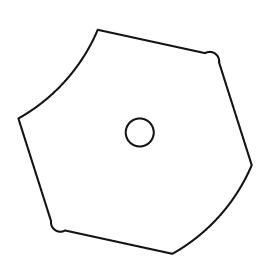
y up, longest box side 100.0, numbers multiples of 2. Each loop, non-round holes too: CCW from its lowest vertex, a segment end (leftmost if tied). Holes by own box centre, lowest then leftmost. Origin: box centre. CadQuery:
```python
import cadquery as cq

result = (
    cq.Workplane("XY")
    .moveTo(16.0, -48.0)
    .threePointArc((36.0, -32.0), (50.0, -10.0))
    .lineTo(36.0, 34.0)
    .threePointArc((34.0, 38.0), (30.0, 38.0))
    .lineTo(-16.0, 48.0)
    .threePointArc((-30.0, 26.0), (-50.0, 10.0))
    .lineTo(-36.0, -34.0)
    .threePointArc((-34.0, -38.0), (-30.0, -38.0))
    .close()
    .moveTo(2.0, 4.0)
    .circle(6.0)
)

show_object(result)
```